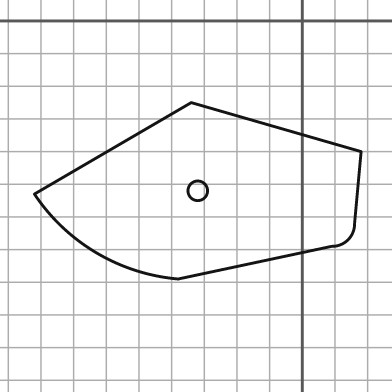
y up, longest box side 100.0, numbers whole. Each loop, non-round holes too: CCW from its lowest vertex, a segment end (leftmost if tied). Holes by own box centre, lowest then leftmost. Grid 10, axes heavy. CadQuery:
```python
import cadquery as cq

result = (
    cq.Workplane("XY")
    .moveTo(-38.0, -79.0)
    .lineTo(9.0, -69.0)
    .threePointArc((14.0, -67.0), (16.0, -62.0))
    .lineTo(18.0, -40.0)
    .lineTo(-34.0, -25.0)
    .lineTo(-82.0, -53.0)
    .threePointArc((-63.0, -71.0), (-38.0, -79.0))
    .close()
    .moveTo(-32.0, -52.0)
    .circle(3.0)
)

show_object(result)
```